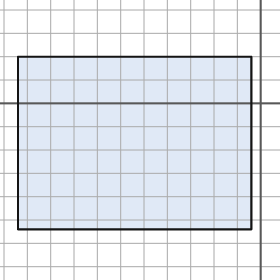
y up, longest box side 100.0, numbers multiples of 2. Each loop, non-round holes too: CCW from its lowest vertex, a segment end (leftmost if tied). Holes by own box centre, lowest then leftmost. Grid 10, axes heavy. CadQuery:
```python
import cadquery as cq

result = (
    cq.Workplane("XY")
    .moveTo(-104.0, -54.0)
    .lineTo(-4.0, -54.0)
    .lineTo(-4.0, 20.0)
    .lineTo(-104.0, 20.0)
    .close()
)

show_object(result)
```